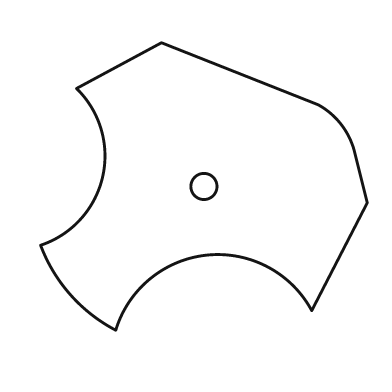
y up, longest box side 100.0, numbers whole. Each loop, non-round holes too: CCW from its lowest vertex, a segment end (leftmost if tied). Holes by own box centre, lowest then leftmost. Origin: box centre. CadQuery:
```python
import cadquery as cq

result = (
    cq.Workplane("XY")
    .moveTo(-27.0, -44.0)
    .threePointArc((1.0, -21.0), (33.0, -38.0))
    .lineTo(50.0, -5.0)
    .lineTo(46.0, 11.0)
    .threePointArc((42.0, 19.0), (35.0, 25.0))
    .lineTo(-13.0, 44.0)
    .lineTo(-39.0, 30.0)
    .threePointArc((-31.0, 3.0), (-50.0, -18.0))
    .threePointArc((-41.0, -33.0), (-27.0, -44.0))
    .close()
    .moveTo(0.0, 0.0)
    .circle(4.0)
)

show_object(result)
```